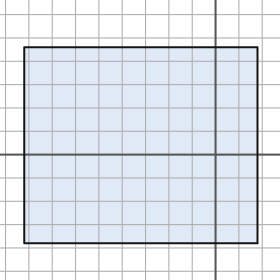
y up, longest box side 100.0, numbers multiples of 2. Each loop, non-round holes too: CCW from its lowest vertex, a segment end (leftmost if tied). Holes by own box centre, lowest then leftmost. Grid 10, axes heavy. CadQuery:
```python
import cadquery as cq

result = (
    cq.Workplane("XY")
    .moveTo(-82.0, -38.0)
    .lineTo(18.0, -38.0)
    .lineTo(18.0, 46.0)
    .lineTo(-82.0, 46.0)
    .close()
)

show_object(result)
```